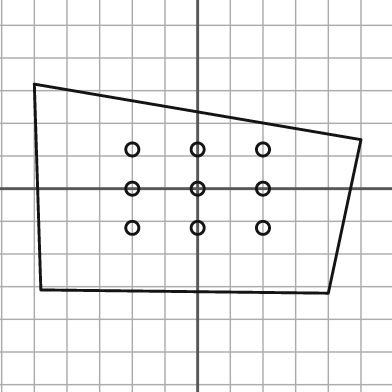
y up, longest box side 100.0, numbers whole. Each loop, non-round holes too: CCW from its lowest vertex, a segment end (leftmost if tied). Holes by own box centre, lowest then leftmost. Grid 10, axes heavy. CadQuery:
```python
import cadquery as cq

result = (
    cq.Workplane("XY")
    .moveTo(40.0, -32.0)
    .lineTo(50.0, 15.0)
    .lineTo(-50.0, 32.0)
    .lineTo(-48.0, -31.0)
    .close()
    .moveTo(-20.0, -12.0)
    .circle(2.0)
    .moveTo(0.0, -12.0)
    .circle(2.0)
    .moveTo(20.0, -12.0)
    .circle(2.0)
    .moveTo(-20.0, 0.0)
    .circle(2.0)
    .moveTo(0.0, 0.0)
    .circle(2.0)
    .moveTo(20.0, 0.0)
    .circle(2.0)
    .moveTo(-20.0, 12.0)
    .circle(2.0)
    .moveTo(0.0, 12.0)
    .circle(2.0)
    .moveTo(20.0, 12.0)
    .circle(2.0)
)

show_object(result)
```